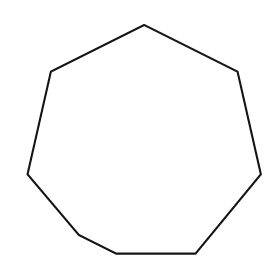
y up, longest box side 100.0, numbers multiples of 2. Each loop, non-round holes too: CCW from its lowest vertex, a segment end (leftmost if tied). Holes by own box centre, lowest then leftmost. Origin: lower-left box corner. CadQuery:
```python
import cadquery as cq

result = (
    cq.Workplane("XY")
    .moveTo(38.0, 0.0)
    .lineTo(72.0, 0.0)
    .lineTo(100.0, 34.0)
    .lineTo(90.0, 78.0)
    .lineTo(50.0, 98.0)
    .lineTo(10.0, 78.0)
    .lineTo(0.0, 34.0)
    .lineTo(22.0, 8.0)
    .close()
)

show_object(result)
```